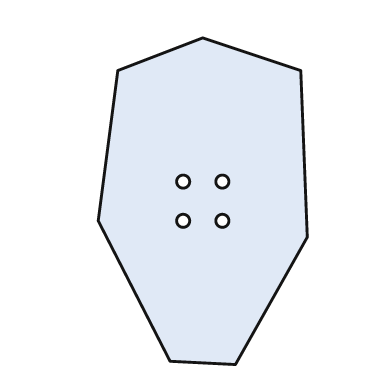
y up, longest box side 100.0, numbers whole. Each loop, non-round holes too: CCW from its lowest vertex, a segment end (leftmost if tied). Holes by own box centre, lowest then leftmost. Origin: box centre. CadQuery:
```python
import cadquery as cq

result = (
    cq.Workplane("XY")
    .moveTo(10.0, -50.0)
    .lineTo(32.0, -11.0)
    .lineTo(30.0, 40.0)
    .lineTo(0.0, 50.0)
    .lineTo(-26.0, 40.0)
    .lineTo(-32.0, -6.0)
    .lineTo(-10.0, -49.0)
    .close()
    .moveTo(-6.0, -6.0)
    .circle(2.0)
    .moveTo(6.0, -6.0)
    .circle(2.0)
    .moveTo(-6.0, 6.0)
    .circle(2.0)
    .moveTo(6.0, 6.0)
    .circle(2.0)
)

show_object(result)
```